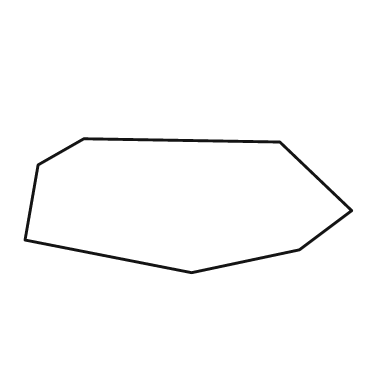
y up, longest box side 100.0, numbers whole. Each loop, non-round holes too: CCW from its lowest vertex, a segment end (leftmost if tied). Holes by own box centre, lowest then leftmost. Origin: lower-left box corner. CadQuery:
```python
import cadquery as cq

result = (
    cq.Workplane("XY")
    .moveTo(51.0, 0.0)
    .lineTo(84.0, 7.0)
    .lineTo(100.0, 19.0)
    .lineTo(78.0, 40.0)
    .lineTo(18.0, 41.0)
    .lineTo(4.0, 33.0)
    .lineTo(0.0, 10.0)
    .close()
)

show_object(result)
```